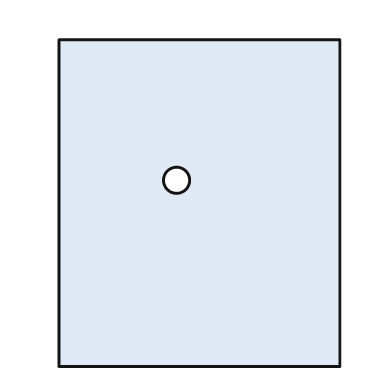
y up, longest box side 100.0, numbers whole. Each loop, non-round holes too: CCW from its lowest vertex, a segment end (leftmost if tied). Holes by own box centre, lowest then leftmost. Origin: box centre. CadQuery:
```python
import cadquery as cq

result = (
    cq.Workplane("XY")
    .moveTo(-43.0, -50.0)
    .lineTo(43.0, -50.0)
    .lineTo(43.0, 50.0)
    .lineTo(-43.0, 50.0)
    .close()
    .moveTo(-7.0, 7.0)
    .circle(4.0)
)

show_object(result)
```